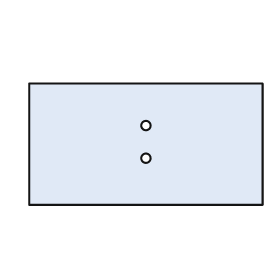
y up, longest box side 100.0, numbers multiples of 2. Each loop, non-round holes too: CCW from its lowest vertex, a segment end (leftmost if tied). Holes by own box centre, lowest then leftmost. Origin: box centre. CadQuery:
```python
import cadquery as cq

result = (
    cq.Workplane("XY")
    .moveTo(-50.0, -26.0)
    .lineTo(50.0, -26.0)
    .lineTo(50.0, 26.0)
    .lineTo(-50.0, 26.0)
    .close()
    .moveTo(0.0, -6.0)
    .circle(2.0)
    .moveTo(0.0, 8.0)
    .circle(2.0)
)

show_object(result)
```